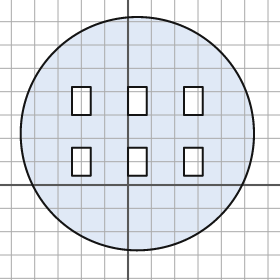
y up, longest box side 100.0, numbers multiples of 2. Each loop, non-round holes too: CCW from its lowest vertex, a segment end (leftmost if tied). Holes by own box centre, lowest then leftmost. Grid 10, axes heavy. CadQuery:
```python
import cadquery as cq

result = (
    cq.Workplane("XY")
    .moveTo(4.0, 22.0)
    .circle(50.0)
    .moveTo(-24.0, 4.0)
    .lineTo(-16.0, 4.0)
    .lineTo(-16.0, 16.0)
    .lineTo(-24.0, 16.0)
    .close()
    .moveTo(0.0, 4.0)
    .lineTo(8.0, 4.0)
    .lineTo(8.0, 16.0)
    .lineTo(0.0, 16.0)
    .close()
    .moveTo(24.0, 4.0)
    .lineTo(32.0, 4.0)
    .lineTo(32.0, 16.0)
    .lineTo(24.0, 16.0)
    .close()
    .moveTo(-24.0, 30.0)
    .lineTo(-16.0, 30.0)
    .lineTo(-16.0, 42.0)
    .lineTo(-24.0, 42.0)
    .close()
    .moveTo(0.0, 30.0)
    .lineTo(8.0, 30.0)
    .lineTo(8.0, 42.0)
    .lineTo(0.0, 42.0)
    .close()
    .moveTo(24.0, 30.0)
    .lineTo(32.0, 30.0)
    .lineTo(32.0, 42.0)
    .lineTo(24.0, 42.0)
    .close()
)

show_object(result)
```